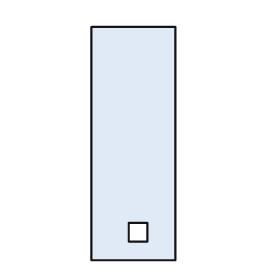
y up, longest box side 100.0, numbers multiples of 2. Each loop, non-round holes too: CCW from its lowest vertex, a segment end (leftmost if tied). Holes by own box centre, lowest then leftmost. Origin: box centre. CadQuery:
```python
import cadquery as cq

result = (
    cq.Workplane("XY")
    .moveTo(-18.0, -50.0)
    .lineTo(18.0, -50.0)
    .lineTo(18.0, 50.0)
    .lineTo(-18.0, 50.0)
    .close()
    .moveTo(-2.0, -42.0)
    .lineTo(6.0, -42.0)
    .lineTo(6.0, -34.0)
    .lineTo(-2.0, -34.0)
    .close()
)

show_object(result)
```